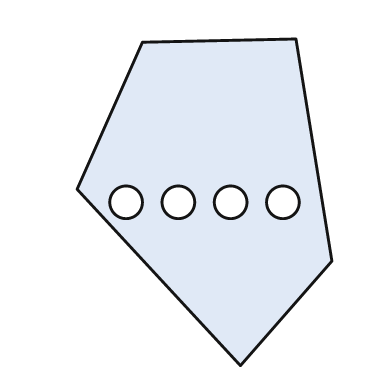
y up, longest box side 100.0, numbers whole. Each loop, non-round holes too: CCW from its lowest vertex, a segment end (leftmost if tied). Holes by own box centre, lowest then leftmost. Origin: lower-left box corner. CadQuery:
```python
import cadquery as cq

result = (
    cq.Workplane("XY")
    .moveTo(50.0, 0.0)
    .lineTo(78.0, 32.0)
    .lineTo(67.0, 100.0)
    .lineTo(20.0, 99.0)
    .lineTo(0.0, 54.0)
    .close()
    .moveTo(15.0, 50.0)
    .circle(5.0)
    .moveTo(31.0, 50.0)
    .circle(5.0)
    .moveTo(47.0, 50.0)
    .circle(5.0)
    .moveTo(63.0, 50.0)
    .circle(5.0)
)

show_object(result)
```